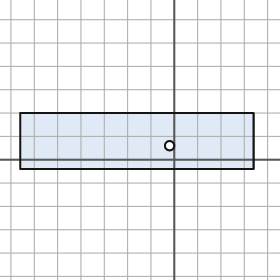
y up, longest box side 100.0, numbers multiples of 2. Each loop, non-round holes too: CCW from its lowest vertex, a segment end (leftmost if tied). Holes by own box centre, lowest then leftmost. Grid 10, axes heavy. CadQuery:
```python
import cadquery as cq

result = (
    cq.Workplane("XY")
    .moveTo(-66.0, -4.0)
    .lineTo(34.0, -4.0)
    .lineTo(34.0, 20.0)
    .lineTo(-66.0, 20.0)
    .close()
    .moveTo(-2.0, 6.0)
    .circle(2.0)
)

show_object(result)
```